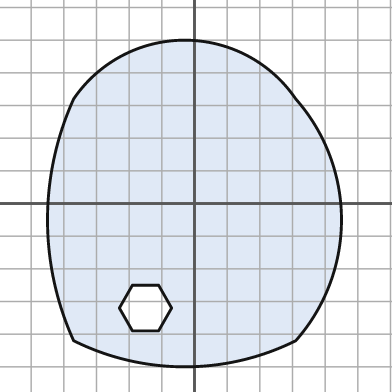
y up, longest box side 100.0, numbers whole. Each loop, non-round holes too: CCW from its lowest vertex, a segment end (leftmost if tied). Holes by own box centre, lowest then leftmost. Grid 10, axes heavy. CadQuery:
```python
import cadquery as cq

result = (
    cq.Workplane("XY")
    .moveTo(-37.0, -42.0)
    .threePointArc((-3.0, -50.0), (31.0, -42.0))
    .threePointArc((45.0, -5.0), (31.0, 32.0))
    .threePointArc((-3.0, 50.0), (-37.0, 32.0))
    .threePointArc((-45.0, -5.0), (-37.0, -42.0))
    .close()
    .moveTo(-19.0, -39.0)
    .lineTo(-11.0, -39.0)
    .lineTo(-7.0, -32.0)
    .lineTo(-11.0, -25.0)
    .lineTo(-19.0, -25.0)
    .lineTo(-23.0, -32.0)
    .close()
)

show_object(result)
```